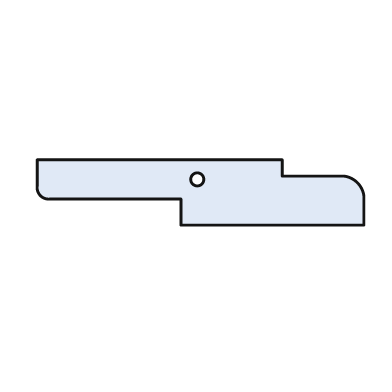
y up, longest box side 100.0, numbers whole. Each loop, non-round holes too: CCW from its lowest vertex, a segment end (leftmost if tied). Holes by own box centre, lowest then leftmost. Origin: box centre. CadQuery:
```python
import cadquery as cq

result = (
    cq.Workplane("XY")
    .moveTo(-6.0, -10.0)
    .lineTo(50.0, -10.0)
    .lineTo(50.0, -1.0)
    .threePointArc((48.0, 3.0), (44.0, 5.0))
    .lineTo(25.0, 5.0)
    .lineTo(25.0, 10.0)
    .lineTo(-50.0, 10.0)
    .lineTo(-50.0, 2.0)
    .threePointArc((-49.0, -1.0), (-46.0, -2.0))
    .lineTo(-6.0, -2.0)
    .close()
    .moveTo(-1.0, 4.0)
    .circle(2.0)
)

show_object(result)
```